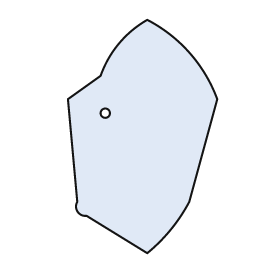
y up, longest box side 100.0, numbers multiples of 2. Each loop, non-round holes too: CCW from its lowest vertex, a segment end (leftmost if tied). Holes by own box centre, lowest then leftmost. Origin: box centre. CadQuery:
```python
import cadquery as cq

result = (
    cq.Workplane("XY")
    .moveTo(2.0, -50.0)
    .threePointArc((12.0, -40.0), (20.0, -28.0))
    .lineTo(32.0, 16.0)
    .threePointArc((20.0, 36.0), (2.0, 50.0))
    .threePointArc((-10.0, 40.0), (-18.0, 26.0))
    .lineTo(-32.0, 16.0)
    .lineTo(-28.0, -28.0)
    .threePointArc((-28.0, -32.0), (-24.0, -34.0))
    .close()
    .moveTo(-16.0, 10.0)
    .circle(2.0)
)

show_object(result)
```